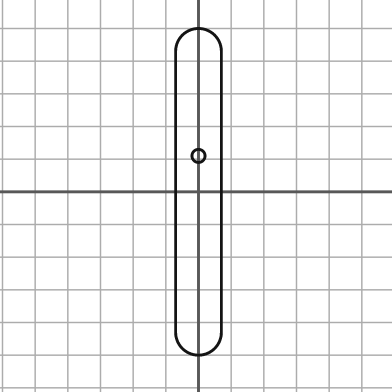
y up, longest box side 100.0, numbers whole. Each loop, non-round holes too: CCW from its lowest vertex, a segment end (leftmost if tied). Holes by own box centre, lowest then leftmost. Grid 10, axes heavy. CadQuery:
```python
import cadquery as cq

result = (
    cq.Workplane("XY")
    .moveTo(-7.0, -43.0)
    .threePointArc((0.0, -50.0), (7.0, -43.0))
    .lineTo(7.0, 43.0)
    .threePointArc((0.0, 50.0), (-7.0, 43.0))
    .close()
    .moveTo(0.0, 11.0)
    .circle(2.0)
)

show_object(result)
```